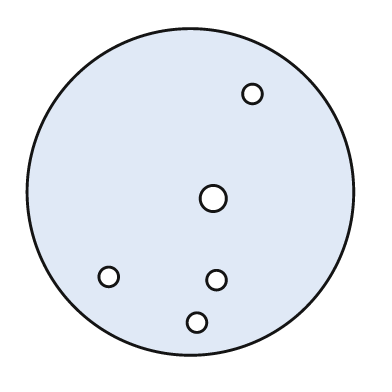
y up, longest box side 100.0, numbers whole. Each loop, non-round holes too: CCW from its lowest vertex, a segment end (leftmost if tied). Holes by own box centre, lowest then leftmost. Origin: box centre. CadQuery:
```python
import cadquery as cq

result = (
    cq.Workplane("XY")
    .moveTo(0.0, 0.0)
    .circle(50.0)
    .moveTo(2.0, -40.0)
    .circle(3.0)
    .moveTo(8.0, -27.0)
    .circle(3.0)
    .moveTo(-25.0, -26.0)
    .circle(3.0)
    .moveTo(7.0, -2.0)
    .circle(4.0)
    .moveTo(19.0, 30.0)
    .circle(3.0)
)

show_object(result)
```